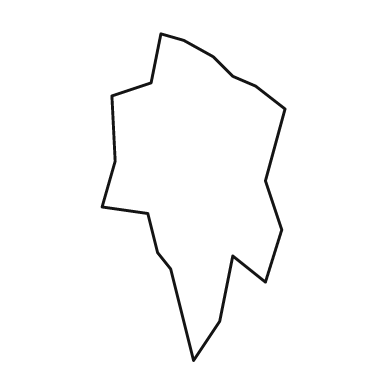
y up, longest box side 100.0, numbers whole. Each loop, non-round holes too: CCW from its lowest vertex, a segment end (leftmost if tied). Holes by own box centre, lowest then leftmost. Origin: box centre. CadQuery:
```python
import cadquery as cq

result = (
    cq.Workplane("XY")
    .moveTo(0.0, -50.0)
    .lineTo(8.0, -38.0)
    .lineTo(12.0, -18.0)
    .lineTo(22.0, -26.0)
    .lineTo(27.0, -10.0)
    .lineTo(22.0, 5.0)
    .lineTo(28.0, 27.0)
    .lineTo(19.0, 34.0)
    .lineTo(12.0, 37.0)
    .lineTo(6.0, 43.0)
    .lineTo(-3.0, 48.0)
    .lineTo(-10.0, 50.0)
    .lineTo(-13.0, 35.0)
    .lineTo(-25.0, 31.0)
    .lineTo(-24.0, 11.0)
    .lineTo(-28.0, -3.0)
    .lineTo(-14.0, -5.0)
    .lineTo(-11.0, -17.0)
    .lineTo(-7.0, -22.0)
    .close()
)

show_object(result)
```